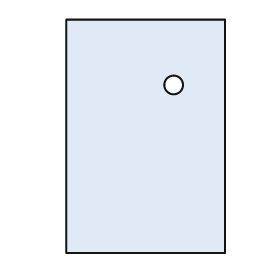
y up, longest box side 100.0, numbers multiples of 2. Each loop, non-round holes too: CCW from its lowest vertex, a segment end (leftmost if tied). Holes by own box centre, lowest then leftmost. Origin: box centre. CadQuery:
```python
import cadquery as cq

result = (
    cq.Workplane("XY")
    .moveTo(-34.0, -50.0)
    .lineTo(34.0, -50.0)
    .lineTo(34.0, 50.0)
    .lineTo(-34.0, 50.0)
    .close()
    .moveTo(12.0, 22.0)
    .circle(4.0)
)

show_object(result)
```